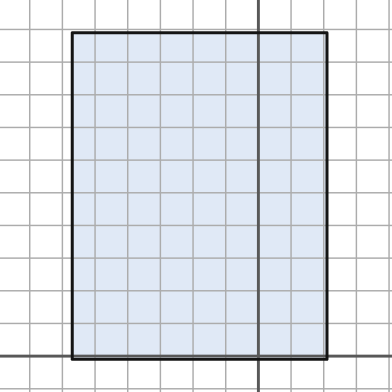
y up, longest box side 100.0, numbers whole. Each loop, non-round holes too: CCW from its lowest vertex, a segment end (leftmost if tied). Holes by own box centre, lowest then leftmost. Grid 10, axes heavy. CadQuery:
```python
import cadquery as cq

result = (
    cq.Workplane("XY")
    .moveTo(-57.0, -1.0)
    .lineTo(21.0, -1.0)
    .lineTo(21.0, 99.0)
    .lineTo(-57.0, 99.0)
    .close()
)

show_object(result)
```